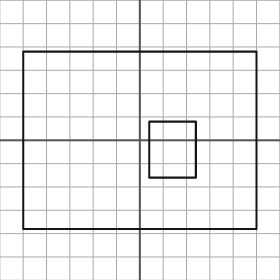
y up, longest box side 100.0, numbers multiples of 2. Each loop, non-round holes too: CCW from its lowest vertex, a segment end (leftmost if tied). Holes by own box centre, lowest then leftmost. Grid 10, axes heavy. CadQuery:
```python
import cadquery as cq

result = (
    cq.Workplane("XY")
    .moveTo(-50.0, -38.0)
    .lineTo(50.0, -38.0)
    .lineTo(50.0, 38.0)
    .lineTo(-50.0, 38.0)
    .close()
    .moveTo(4.0, -16.0)
    .lineTo(24.0, -16.0)
    .lineTo(24.0, 8.0)
    .lineTo(4.0, 8.0)
    .close()
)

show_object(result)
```